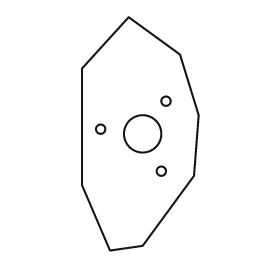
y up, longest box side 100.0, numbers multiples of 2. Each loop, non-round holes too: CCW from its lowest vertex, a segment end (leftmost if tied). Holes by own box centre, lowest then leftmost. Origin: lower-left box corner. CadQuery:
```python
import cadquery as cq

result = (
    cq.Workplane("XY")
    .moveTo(12.0, 0.0)
    .lineTo(26.0, 2.0)
    .lineTo(48.0, 32.0)
    .lineTo(50.0, 58.0)
    .lineTo(42.0, 84.0)
    .lineTo(20.0, 100.0)
    .lineTo(0.0, 78.0)
    .lineTo(0.0, 28.0)
    .close()
    .moveTo(34.0, 34.0)
    .circle(2.0)
    .moveTo(26.0, 50.0)
    .circle(8.0)
    .moveTo(8.0, 52.0)
    .circle(2.0)
    .moveTo(36.0, 64.0)
    .circle(2.0)
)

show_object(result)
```